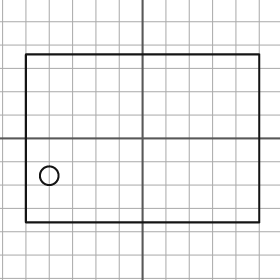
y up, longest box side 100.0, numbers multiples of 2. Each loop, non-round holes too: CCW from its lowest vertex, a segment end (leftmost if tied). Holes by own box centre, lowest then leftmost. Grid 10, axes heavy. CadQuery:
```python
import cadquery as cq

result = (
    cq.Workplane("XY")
    .moveTo(-50.0, -36.0)
    .lineTo(50.0, -36.0)
    .lineTo(50.0, 36.0)
    .lineTo(-50.0, 36.0)
    .close()
    .moveTo(-40.0, -16.0)
    .circle(4.0)
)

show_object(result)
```